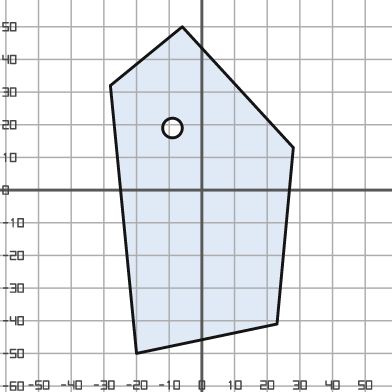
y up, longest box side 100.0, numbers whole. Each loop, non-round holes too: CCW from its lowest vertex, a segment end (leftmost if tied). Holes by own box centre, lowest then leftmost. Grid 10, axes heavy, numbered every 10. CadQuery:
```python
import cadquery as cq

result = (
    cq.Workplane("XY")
    .moveTo(-20.0, -50.0)
    .lineTo(23.0, -41.0)
    .lineTo(28.0, 13.0)
    .lineTo(-6.0, 50.0)
    .lineTo(-28.0, 32.0)
    .close()
    .moveTo(-9.0, 19.0)
    .circle(3.0)
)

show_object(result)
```